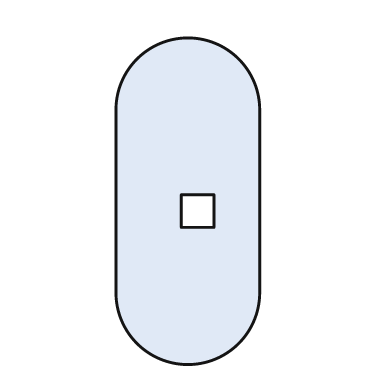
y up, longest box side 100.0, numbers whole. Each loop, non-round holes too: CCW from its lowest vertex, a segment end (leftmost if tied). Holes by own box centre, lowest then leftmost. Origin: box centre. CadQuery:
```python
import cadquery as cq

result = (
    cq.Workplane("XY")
    .moveTo(-22.0, -28.0)
    .threePointArc((0.0, -50.0), (22.0, -28.0))
    .lineTo(22.0, 28.0)
    .threePointArc((0.0, 50.0), (-22.0, 28.0))
    .close()
    .moveTo(-2.0, -8.0)
    .lineTo(8.0, -8.0)
    .lineTo(8.0, 2.0)
    .lineTo(-2.0, 2.0)
    .close()
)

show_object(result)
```